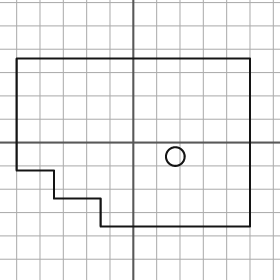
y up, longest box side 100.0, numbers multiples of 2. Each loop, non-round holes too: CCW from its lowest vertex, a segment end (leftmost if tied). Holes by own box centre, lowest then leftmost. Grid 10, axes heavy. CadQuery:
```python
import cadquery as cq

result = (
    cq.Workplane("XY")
    .moveTo(-14.0, -36.0)
    .lineTo(50.0, -36.0)
    .lineTo(50.0, 36.0)
    .lineTo(-50.0, 36.0)
    .lineTo(-50.0, -12.0)
    .lineTo(-34.0, -12.0)
    .lineTo(-34.0, -24.0)
    .lineTo(-14.0, -24.0)
    .close()
    .moveTo(18.0, -6.0)
    .circle(4.0)
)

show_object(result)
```